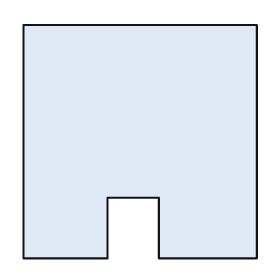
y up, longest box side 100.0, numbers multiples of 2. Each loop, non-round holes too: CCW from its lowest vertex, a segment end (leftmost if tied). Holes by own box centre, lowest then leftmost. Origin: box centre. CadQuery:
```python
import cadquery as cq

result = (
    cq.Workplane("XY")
    .moveTo(-50.0, -50.0)
    .lineTo(-14.0, -50.0)
    .lineTo(-14.0, -24.0)
    .lineTo(8.0, -24.0)
    .lineTo(8.0, -50.0)
    .lineTo(50.0, -50.0)
    .lineTo(50.0, 50.0)
    .lineTo(-50.0, 50.0)
    .close()
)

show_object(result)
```